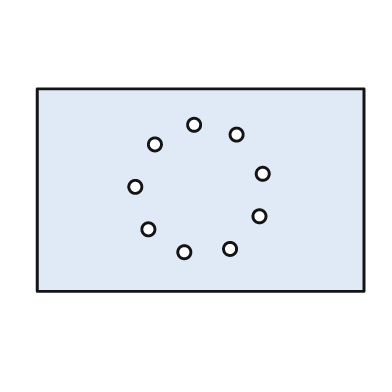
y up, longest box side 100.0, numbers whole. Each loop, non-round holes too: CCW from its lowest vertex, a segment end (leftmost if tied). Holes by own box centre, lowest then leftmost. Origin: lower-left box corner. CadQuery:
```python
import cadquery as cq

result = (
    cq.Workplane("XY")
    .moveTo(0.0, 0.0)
    .lineTo(100.0, 0.0)
    .lineTo(100.0, 62.0)
    .lineTo(0.0, 62.0)
    .close()
    .moveTo(45.0, 12.0)
    .circle(2.0)
    .moveTo(59.0, 13.0)
    .circle(2.0)
    .moveTo(34.0, 19.0)
    .circle(2.0)
    .moveTo(68.0, 23.0)
    .circle(2.0)
    .moveTo(30.0, 32.0)
    .circle(2.0)
    .moveTo(69.0, 36.0)
    .circle(2.0)
    .moveTo(36.0, 45.0)
    .circle(2.0)
    .moveTo(61.0, 48.0)
    .circle(2.0)
    .moveTo(48.0, 51.0)
    .circle(2.0)
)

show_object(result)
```